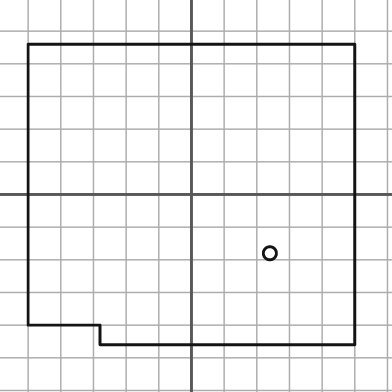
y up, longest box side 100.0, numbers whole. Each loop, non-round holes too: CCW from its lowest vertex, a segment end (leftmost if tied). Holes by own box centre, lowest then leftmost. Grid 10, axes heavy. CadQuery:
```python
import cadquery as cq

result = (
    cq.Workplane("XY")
    .moveTo(-28.0, -46.0)
    .lineTo(50.0, -46.0)
    .lineTo(50.0, 46.0)
    .lineTo(-50.0, 46.0)
    .lineTo(-50.0, -40.0)
    .lineTo(-28.0, -40.0)
    .close()
    .moveTo(24.0, -18.0)
    .circle(2.0)
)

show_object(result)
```